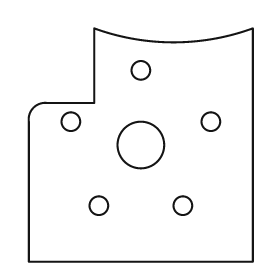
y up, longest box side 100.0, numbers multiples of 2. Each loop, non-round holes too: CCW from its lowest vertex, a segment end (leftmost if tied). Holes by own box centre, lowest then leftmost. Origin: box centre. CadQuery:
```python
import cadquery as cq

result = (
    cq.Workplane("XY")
    .moveTo(-48.0, -50.0)
    .lineTo(48.0, -50.0)
    .lineTo(48.0, 50.0)
    .threePointArc((14.0, 44.0), (-20.0, 50.0))
    .lineTo(-20.0, 18.0)
    .lineTo(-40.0, 18.0)
    .threePointArc((-46.0, 16.0), (-48.0, 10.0))
    .close()
    .moveTo(-18.0, -26.0)
    .circle(4.0)
    .moveTo(18.0, -26.0)
    .circle(4.0)
    .moveTo(0.0, 0.0)
    .circle(10.0)
    .moveTo(-30.0, 10.0)
    .circle(4.0)
    .moveTo(30.0, 10.0)
    .circle(4.0)
    .moveTo(0.0, 32.0)
    .circle(4.0)
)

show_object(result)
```